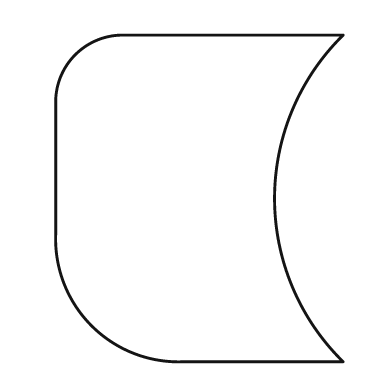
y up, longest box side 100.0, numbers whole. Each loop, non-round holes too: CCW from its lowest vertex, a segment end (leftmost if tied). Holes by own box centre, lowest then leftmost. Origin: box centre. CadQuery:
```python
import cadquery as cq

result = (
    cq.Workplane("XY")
    .moveTo(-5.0, -50.0)
    .lineTo(44.0, -50.0)
    .threePointArc((23.0, 0.0), (44.0, 50.0))
    .lineTo(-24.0, 50.0)
    .threePointArc((-38.0, 44.0), (-44.0, 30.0))
    .lineTo(-44.0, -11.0)
    .threePointArc((-33.0, -39.0), (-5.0, -50.0))
    .close()
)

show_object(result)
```